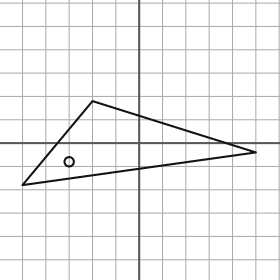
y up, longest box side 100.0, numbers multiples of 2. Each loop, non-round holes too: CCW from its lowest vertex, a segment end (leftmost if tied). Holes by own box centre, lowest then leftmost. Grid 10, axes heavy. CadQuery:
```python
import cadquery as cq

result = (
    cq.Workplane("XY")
    .moveTo(-50.0, -18.0)
    .lineTo(50.0, -4.0)
    .lineTo(-20.0, 18.0)
    .close()
    .moveTo(-30.0, -8.0)
    .circle(2.0)
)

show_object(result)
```